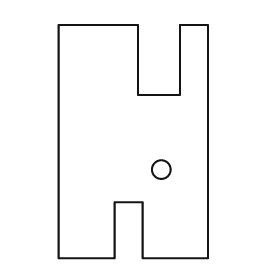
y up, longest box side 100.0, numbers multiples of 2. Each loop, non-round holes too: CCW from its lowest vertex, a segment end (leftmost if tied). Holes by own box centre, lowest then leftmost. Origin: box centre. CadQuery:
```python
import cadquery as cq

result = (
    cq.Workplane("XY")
    .moveTo(-32.0, -50.0)
    .lineTo(-8.0, -50.0)
    .lineTo(-8.0, -26.0)
    .lineTo(4.0, -26.0)
    .lineTo(4.0, -50.0)
    .lineTo(32.0, -50.0)
    .lineTo(32.0, 50.0)
    .lineTo(20.0, 50.0)
    .lineTo(20.0, 20.0)
    .lineTo(2.0, 20.0)
    .lineTo(2.0, 50.0)
    .lineTo(-32.0, 50.0)
    .close()
    .moveTo(12.0, -12.0)
    .circle(4.0)
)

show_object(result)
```